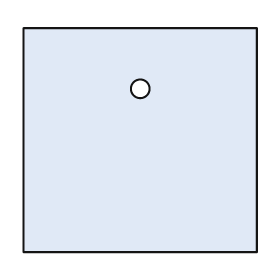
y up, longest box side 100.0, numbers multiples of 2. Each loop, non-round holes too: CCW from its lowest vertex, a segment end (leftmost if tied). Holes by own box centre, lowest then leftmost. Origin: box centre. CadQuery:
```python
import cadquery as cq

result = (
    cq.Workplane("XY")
    .moveTo(-50.0, -48.0)
    .lineTo(50.0, -48.0)
    .lineTo(50.0, 48.0)
    .lineTo(-50.0, 48.0)
    .close()
    .moveTo(0.0, 22.0)
    .circle(4.0)
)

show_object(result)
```